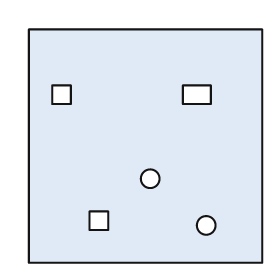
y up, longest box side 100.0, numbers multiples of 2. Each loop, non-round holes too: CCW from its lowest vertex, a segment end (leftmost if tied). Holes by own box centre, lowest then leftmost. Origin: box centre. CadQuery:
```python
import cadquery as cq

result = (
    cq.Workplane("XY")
    .moveTo(-50.0, -50.0)
    .lineTo(50.0, -50.0)
    .lineTo(50.0, 50.0)
    .lineTo(-50.0, 50.0)
    .close()
    .moveTo(26.0, -34.0)
    .circle(4.0)
    .moveTo(-24.0, -36.0)
    .lineTo(-16.0, -36.0)
    .lineTo(-16.0, -28.0)
    .lineTo(-24.0, -28.0)
    .close()
    .moveTo(2.0, -14.0)
    .circle(4.0)
    .moveTo(-40.0, 18.0)
    .lineTo(-32.0, 18.0)
    .lineTo(-32.0, 26.0)
    .lineTo(-40.0, 26.0)
    .close()
    .moveTo(16.0, 18.0)
    .lineTo(28.0, 18.0)
    .lineTo(28.0, 26.0)
    .lineTo(16.0, 26.0)
    .close()
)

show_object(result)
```